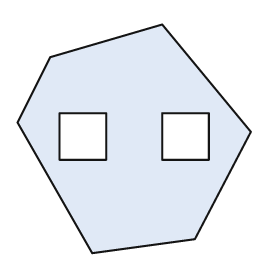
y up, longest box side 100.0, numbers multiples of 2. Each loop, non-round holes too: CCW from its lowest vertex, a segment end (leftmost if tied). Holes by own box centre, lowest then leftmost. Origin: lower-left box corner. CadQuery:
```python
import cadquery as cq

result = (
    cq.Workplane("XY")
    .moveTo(32.0, 0.0)
    .lineTo(76.0, 6.0)
    .lineTo(100.0, 52.0)
    .lineTo(62.0, 98.0)
    .lineTo(14.0, 84.0)
    .lineTo(0.0, 56.0)
    .close()
    .moveTo(18.0, 40.0)
    .lineTo(38.0, 40.0)
    .lineTo(38.0, 60.0)
    .lineTo(18.0, 60.0)
    .close()
    .moveTo(62.0, 40.0)
    .lineTo(82.0, 40.0)
    .lineTo(82.0, 60.0)
    .lineTo(62.0, 60.0)
    .close()
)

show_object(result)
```